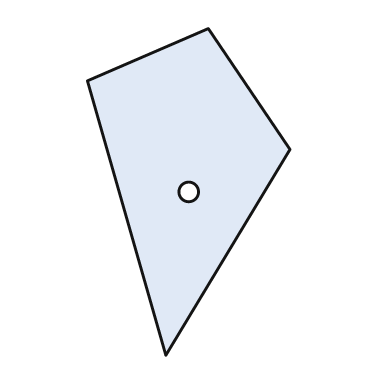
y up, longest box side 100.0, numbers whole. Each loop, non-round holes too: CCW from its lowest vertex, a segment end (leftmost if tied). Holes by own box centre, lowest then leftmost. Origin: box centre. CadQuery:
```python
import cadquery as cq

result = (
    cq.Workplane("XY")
    .moveTo(-7.0, -50.0)
    .lineTo(31.0, 13.0)
    .lineTo(6.0, 50.0)
    .lineTo(-31.0, 34.0)
    .close()
    .moveTo(0.0, 0.0)
    .circle(3.0)
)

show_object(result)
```